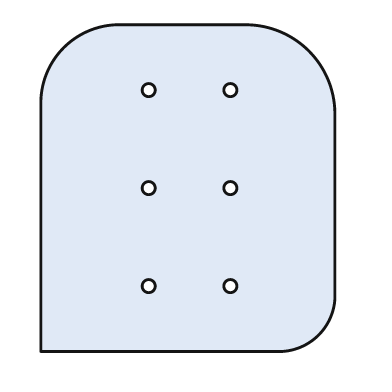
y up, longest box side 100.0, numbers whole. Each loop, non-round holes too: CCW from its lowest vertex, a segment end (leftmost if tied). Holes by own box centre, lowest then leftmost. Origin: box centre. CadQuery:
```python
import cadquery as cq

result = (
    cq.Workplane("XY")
    .moveTo(-45.0, -50.0)
    .lineTo(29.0, -50.0)
    .threePointArc((40.0, -45.0), (45.0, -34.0))
    .lineTo(45.0, 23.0)
    .threePointArc((37.0, 42.0), (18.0, 50.0))
    .lineTo(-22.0, 50.0)
    .threePointArc((-38.0, 43.0), (-45.0, 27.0))
    .close()
    .moveTo(-12.0, -30.0)
    .circle(2.0)
    .moveTo(13.0, -30.0)
    .circle(2.0)
    .moveTo(-12.0, 0.0)
    .circle(2.0)
    .moveTo(13.0, 0.0)
    .circle(2.0)
    .moveTo(-12.0, 30.0)
    .circle(2.0)
    .moveTo(13.0, 30.0)
    .circle(2.0)
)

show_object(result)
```